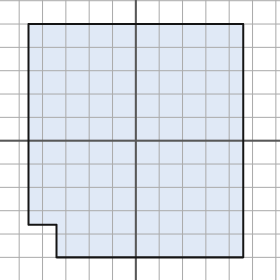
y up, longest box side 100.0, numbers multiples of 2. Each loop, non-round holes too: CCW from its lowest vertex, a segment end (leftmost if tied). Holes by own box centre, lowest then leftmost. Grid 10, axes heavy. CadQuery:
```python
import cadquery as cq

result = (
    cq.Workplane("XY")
    .moveTo(-34.0, -50.0)
    .lineTo(46.0, -50.0)
    .lineTo(46.0, 50.0)
    .lineTo(-46.0, 50.0)
    .lineTo(-46.0, -36.0)
    .lineTo(-34.0, -36.0)
    .close()
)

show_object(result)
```